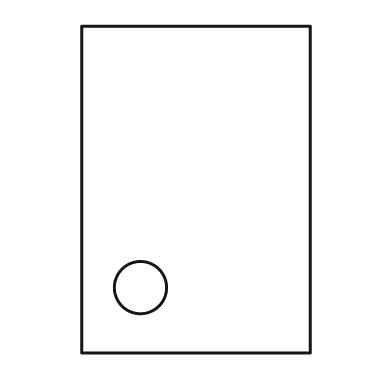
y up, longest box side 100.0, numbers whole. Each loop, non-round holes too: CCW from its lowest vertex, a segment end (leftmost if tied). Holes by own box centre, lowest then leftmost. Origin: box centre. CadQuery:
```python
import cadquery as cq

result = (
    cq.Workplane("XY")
    .moveTo(-35.0, -50.0)
    .lineTo(35.0, -50.0)
    .lineTo(35.0, 50.0)
    .lineTo(-35.0, 50.0)
    .close()
    .moveTo(-17.0, -30.0)
    .circle(8.0)
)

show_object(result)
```